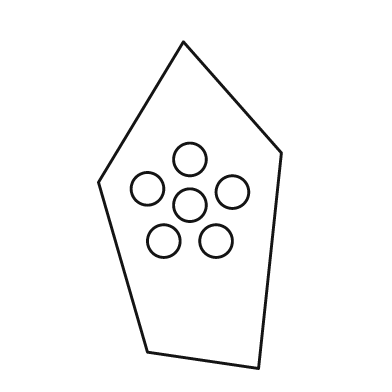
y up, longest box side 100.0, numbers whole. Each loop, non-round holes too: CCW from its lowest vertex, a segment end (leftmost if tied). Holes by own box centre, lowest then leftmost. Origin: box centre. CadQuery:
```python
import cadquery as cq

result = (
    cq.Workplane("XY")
    .moveTo(21.0, -50.0)
    .lineTo(28.0, 16.0)
    .lineTo(-2.0, 50.0)
    .lineTo(-28.0, 7.0)
    .lineTo(-13.0, -45.0)
    .close()
    .moveTo(-8.0, -11.0)
    .circle(5.0)
    .moveTo(8.0, -11.0)
    .circle(5.0)
    .moveTo(0.0, 0.0)
    .circle(5.0)
    .moveTo(13.0, 4.0)
    .circle(5.0)
    .moveTo(-13.0, 5.0)
    .circle(5.0)
    .moveTo(0.0, 14.0)
    .circle(5.0)
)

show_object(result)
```